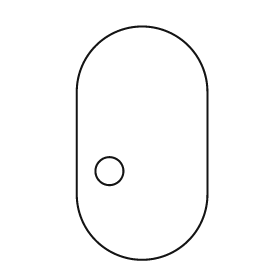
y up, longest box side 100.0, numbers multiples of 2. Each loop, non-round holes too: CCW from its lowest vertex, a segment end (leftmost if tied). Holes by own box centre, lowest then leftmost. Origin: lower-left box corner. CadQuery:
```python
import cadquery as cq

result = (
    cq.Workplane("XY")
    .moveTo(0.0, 28.0)
    .threePointArc((28.0, 0.0), (56.0, 28.0))
    .lineTo(56.0, 72.0)
    .threePointArc((28.0, 100.0), (0.0, 72.0))
    .close()
    .moveTo(14.0, 38.0)
    .circle(6.0)
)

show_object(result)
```